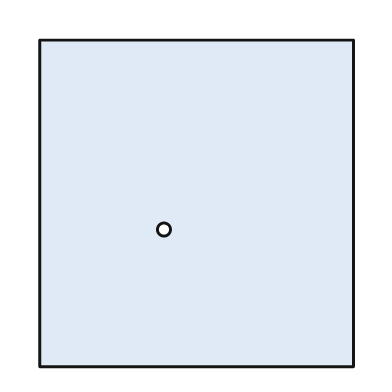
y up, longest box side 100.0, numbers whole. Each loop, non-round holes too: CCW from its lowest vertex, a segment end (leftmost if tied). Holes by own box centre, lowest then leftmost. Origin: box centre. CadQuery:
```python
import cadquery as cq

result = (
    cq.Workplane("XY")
    .moveTo(-48.0, -50.0)
    .lineTo(48.0, -50.0)
    .lineTo(48.0, 50.0)
    .lineTo(-48.0, 50.0)
    .close()
    .moveTo(-10.0, -8.0)
    .circle(2.0)
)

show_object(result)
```